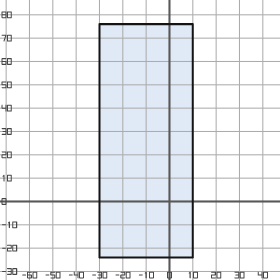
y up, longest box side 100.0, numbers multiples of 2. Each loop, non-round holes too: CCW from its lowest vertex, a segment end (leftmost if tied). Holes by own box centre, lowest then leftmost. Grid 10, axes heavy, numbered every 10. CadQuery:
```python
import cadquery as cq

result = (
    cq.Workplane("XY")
    .moveTo(-30.0, -24.0)
    .lineTo(10.0, -24.0)
    .lineTo(10.0, 76.0)
    .lineTo(-30.0, 76.0)
    .close()
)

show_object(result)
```